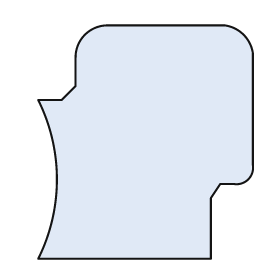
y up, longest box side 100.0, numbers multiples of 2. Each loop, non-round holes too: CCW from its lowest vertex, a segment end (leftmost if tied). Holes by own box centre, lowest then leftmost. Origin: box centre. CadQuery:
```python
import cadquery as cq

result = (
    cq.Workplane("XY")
    .moveTo(-46.0, -50.0)
    .lineTo(28.0, -50.0)
    .lineTo(28.0, -24.0)
    .lineTo(32.0, -18.0)
    .lineTo(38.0, -18.0)
    .threePointArc((44.0, -16.0), (46.0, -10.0))
    .lineTo(46.0, 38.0)
    .threePointArc((42.0, 46.0), (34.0, 50.0))
    .lineTo(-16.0, 50.0)
    .threePointArc((-26.0, 46.0), (-30.0, 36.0))
    .lineTo(-30.0, 24.0)
    .lineTo(-36.0, 18.0)
    .lineTo(-46.0, 18.0)
    .threePointArc((-38.0, -16.0), (-46.0, -50.0))
    .close()
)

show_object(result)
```